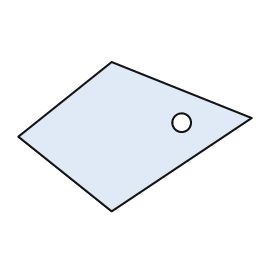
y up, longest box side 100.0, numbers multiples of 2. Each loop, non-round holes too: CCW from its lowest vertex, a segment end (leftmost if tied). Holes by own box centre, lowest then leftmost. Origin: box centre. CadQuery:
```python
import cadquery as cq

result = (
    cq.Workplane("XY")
    .moveTo(-10.0, -32.0)
    .lineTo(50.0, 8.0)
    .lineTo(-10.0, 32.0)
    .lineTo(-50.0, 0.0)
    .close()
    .moveTo(20.0, 6.0)
    .circle(4.0)
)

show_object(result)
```